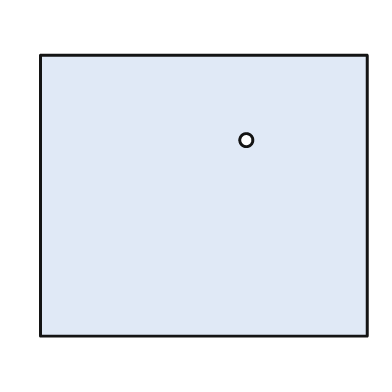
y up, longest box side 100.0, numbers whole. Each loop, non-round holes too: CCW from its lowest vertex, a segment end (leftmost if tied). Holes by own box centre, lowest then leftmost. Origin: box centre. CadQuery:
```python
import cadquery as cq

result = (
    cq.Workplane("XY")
    .moveTo(-50.0, -43.0)
    .lineTo(50.0, -43.0)
    .lineTo(50.0, 43.0)
    .lineTo(-50.0, 43.0)
    .close()
    .moveTo(13.0, 17.0)
    .circle(2.0)
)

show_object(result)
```